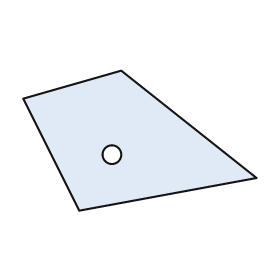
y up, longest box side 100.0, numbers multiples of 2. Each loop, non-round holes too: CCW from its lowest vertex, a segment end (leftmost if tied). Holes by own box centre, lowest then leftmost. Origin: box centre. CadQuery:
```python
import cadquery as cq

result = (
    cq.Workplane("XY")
    .moveTo(-26.0, -30.0)
    .lineTo(50.0, -16.0)
    .lineTo(-8.0, 30.0)
    .lineTo(-50.0, 18.0)
    .close()
    .moveTo(-12.0, -6.0)
    .circle(4.0)
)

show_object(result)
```